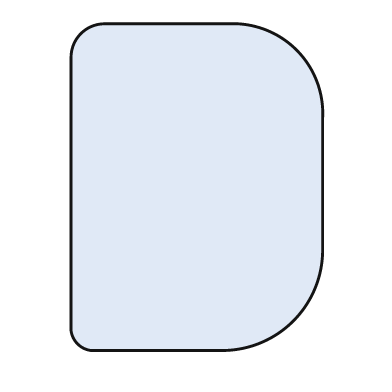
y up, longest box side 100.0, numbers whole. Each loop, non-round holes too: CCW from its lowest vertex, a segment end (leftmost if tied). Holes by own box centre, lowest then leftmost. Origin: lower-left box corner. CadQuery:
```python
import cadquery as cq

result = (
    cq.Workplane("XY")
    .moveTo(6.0, 0.0)
    .lineTo(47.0, 0.0)
    .threePointArc((68.0, 9.0), (77.0, 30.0))
    .lineTo(77.0, 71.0)
    .threePointArc((69.0, 92.0), (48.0, 100.0))
    .lineTo(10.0, 100.0)
    .threePointArc((3.0, 97.0), (0.0, 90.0))
    .lineTo(0.0, 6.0)
    .threePointArc((2.0, 2.0), (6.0, 0.0))
    .close()
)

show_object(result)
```